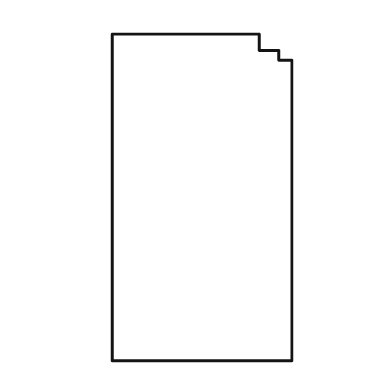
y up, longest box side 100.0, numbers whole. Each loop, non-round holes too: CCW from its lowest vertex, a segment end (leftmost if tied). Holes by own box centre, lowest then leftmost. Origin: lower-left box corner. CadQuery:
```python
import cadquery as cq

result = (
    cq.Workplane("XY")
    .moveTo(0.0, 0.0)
    .lineTo(55.0, 0.0)
    .lineTo(55.0, 92.0)
    .lineTo(51.0, 92.0)
    .lineTo(51.0, 95.0)
    .lineTo(45.0, 95.0)
    .lineTo(45.0, 100.0)
    .lineTo(0.0, 100.0)
    .close()
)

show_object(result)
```